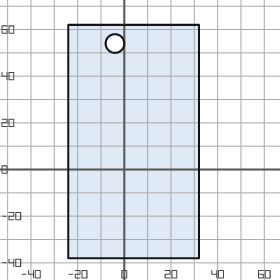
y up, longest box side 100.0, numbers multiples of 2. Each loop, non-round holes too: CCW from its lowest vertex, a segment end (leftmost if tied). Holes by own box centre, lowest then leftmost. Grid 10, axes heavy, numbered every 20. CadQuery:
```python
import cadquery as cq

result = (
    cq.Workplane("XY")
    .moveTo(-24.0, -38.0)
    .lineTo(32.0, -38.0)
    .lineTo(32.0, 62.0)
    .lineTo(-24.0, 62.0)
    .close()
    .moveTo(-4.0, 54.0)
    .circle(4.0)
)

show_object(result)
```